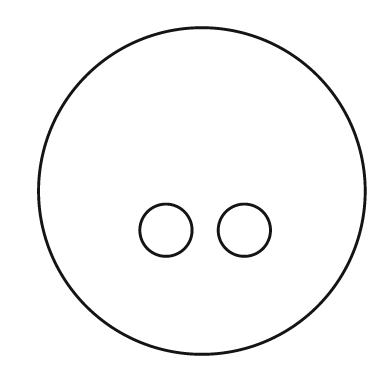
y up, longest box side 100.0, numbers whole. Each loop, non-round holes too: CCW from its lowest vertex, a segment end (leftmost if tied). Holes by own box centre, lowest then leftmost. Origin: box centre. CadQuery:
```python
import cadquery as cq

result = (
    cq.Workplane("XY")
    .moveTo(0.0, 0.0)
    .circle(50.0)
    .moveTo(-11.0, -12.0)
    .circle(8.0)
    .moveTo(13.0, -12.0)
    .circle(8.0)
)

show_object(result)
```